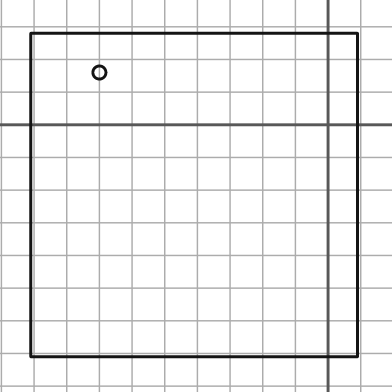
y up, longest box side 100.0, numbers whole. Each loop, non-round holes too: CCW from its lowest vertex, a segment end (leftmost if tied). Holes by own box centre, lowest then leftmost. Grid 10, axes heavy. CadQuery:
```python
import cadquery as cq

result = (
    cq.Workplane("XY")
    .moveTo(-91.0, -71.0)
    .lineTo(9.0, -71.0)
    .lineTo(9.0, 28.0)
    .lineTo(-91.0, 28.0)
    .close()
    .moveTo(-70.0, 16.0)
    .circle(2.0)
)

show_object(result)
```